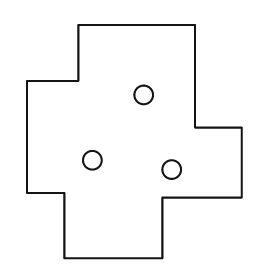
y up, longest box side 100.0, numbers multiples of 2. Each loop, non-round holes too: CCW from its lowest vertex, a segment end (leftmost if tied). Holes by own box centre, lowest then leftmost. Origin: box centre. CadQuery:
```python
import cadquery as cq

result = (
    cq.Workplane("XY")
    .moveTo(-30.0, -50.0)
    .lineTo(12.0, -50.0)
    .lineTo(12.0, -24.0)
    .lineTo(46.0, -24.0)
    .lineTo(46.0, 6.0)
    .lineTo(26.0, 6.0)
    .lineTo(26.0, 50.0)
    .lineTo(-24.0, 50.0)
    .lineTo(-24.0, 26.0)
    .lineTo(-46.0, 26.0)
    .lineTo(-46.0, -22.0)
    .lineTo(-30.0, -22.0)
    .close()
    .moveTo(16.0, -12.0)
    .circle(4.0)
    .moveTo(-18.0, -8.0)
    .circle(4.0)
    .moveTo(4.0, 20.0)
    .circle(4.0)
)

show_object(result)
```